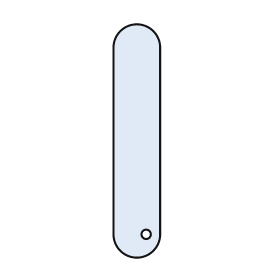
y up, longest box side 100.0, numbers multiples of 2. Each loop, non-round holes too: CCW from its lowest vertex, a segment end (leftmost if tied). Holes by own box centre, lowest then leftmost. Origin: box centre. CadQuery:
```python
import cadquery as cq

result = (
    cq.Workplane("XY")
    .moveTo(-10.0, -40.0)
    .threePointArc((0.0, -50.0), (10.0, -40.0))
    .lineTo(10.0, 40.0)
    .threePointArc((0.0, 50.0), (-10.0, 40.0))
    .close()
    .moveTo(4.0, -40.0)
    .circle(2.0)
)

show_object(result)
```